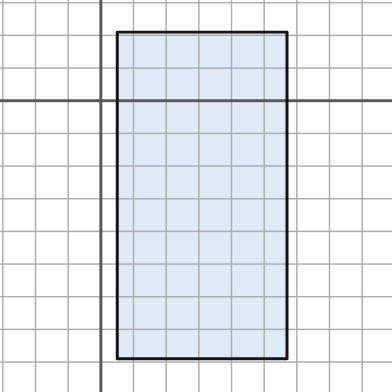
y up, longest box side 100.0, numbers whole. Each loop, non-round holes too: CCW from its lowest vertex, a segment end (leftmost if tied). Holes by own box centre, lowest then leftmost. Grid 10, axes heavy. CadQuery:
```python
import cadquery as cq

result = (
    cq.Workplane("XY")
    .moveTo(5.0, -79.0)
    .lineTo(57.0, -79.0)
    .lineTo(57.0, 21.0)
    .lineTo(5.0, 21.0)
    .close()
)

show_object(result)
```